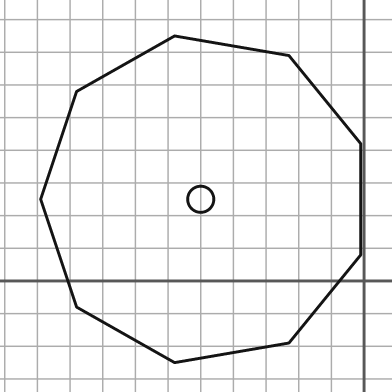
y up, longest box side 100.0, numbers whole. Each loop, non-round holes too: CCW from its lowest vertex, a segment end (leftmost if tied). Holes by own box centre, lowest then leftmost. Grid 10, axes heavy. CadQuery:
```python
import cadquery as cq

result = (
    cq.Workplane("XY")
    .moveTo(-58.0, -25.0)
    .lineTo(-23.0, -19.0)
    .lineTo(-1.0, 8.0)
    .lineTo(-1.0, 42.0)
    .lineTo(-23.0, 69.0)
    .lineTo(-58.0, 75.0)
    .lineTo(-88.0, 58.0)
    .lineTo(-99.0, 25.0)
    .lineTo(-88.0, -8.0)
    .close()
    .moveTo(-50.0, 25.0)
    .circle(4.0)
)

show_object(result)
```